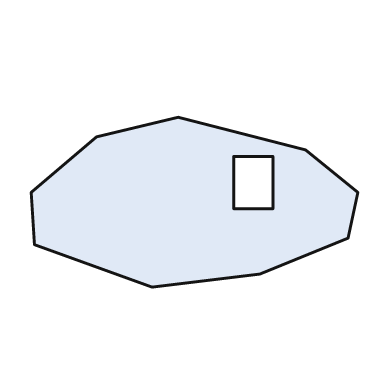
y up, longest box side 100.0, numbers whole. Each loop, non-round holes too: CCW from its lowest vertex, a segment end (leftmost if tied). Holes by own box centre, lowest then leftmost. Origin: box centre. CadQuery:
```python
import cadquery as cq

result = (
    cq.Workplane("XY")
    .moveTo(-13.0, -26.0)
    .lineTo(20.0, -22.0)
    .lineTo(47.0, -11.0)
    .lineTo(50.0, 3.0)
    .lineTo(34.0, 16.0)
    .lineTo(-5.0, 26.0)
    .lineTo(-30.0, 20.0)
    .lineTo(-50.0, 3.0)
    .lineTo(-49.0, -13.0)
    .close()
    .moveTo(12.0, -2.0)
    .lineTo(24.0, -2.0)
    .lineTo(24.0, 14.0)
    .lineTo(12.0, 14.0)
    .close()
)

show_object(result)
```